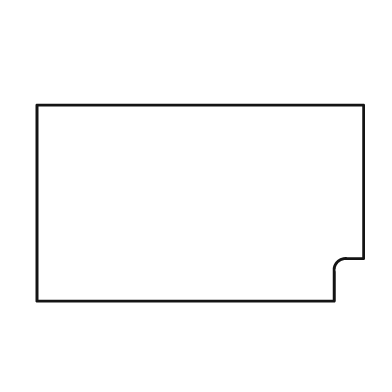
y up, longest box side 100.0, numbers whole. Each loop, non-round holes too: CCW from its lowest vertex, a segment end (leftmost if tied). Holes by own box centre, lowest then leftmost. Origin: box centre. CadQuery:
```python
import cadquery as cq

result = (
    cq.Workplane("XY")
    .moveTo(-50.0, -30.0)
    .lineTo(41.0, -30.0)
    .lineTo(41.0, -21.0)
    .threePointArc((42.0, -18.0), (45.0, -17.0))
    .lineTo(50.0, -17.0)
    .lineTo(50.0, 30.0)
    .lineTo(-50.0, 30.0)
    .close()
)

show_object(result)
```